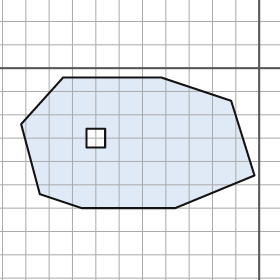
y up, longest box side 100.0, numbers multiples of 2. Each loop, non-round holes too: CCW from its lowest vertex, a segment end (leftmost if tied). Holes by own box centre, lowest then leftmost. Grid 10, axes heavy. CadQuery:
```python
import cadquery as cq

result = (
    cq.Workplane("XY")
    .moveTo(-76.0, -60.0)
    .lineTo(-36.0, -60.0)
    .lineTo(-2.0, -46.0)
    .lineTo(-12.0, -14.0)
    .lineTo(-42.0, -4.0)
    .lineTo(-84.0, -4.0)
    .lineTo(-102.0, -24.0)
    .lineTo(-94.0, -54.0)
    .close()
    .moveTo(-74.0, -34.0)
    .lineTo(-66.0, -34.0)
    .lineTo(-66.0, -26.0)
    .lineTo(-74.0, -26.0)
    .close()
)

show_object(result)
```